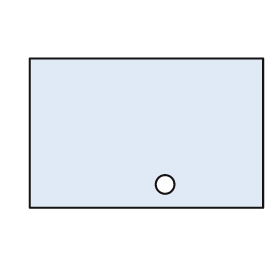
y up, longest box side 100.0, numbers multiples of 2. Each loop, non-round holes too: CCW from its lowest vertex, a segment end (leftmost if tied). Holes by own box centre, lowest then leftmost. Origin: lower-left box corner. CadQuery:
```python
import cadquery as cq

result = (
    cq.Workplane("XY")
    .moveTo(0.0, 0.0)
    .lineTo(100.0, 0.0)
    .lineTo(100.0, 64.0)
    .lineTo(0.0, 64.0)
    .close()
    .moveTo(58.0, 10.0)
    .circle(4.0)
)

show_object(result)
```